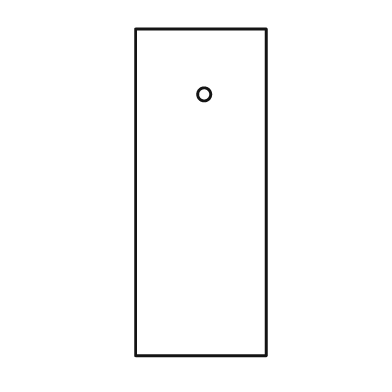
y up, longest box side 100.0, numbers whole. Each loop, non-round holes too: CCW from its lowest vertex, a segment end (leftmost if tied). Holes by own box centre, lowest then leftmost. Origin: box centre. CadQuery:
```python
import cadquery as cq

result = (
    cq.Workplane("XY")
    .moveTo(-20.0, -50.0)
    .lineTo(20.0, -50.0)
    .lineTo(20.0, 50.0)
    .lineTo(-20.0, 50.0)
    .close()
    .moveTo(1.0, 30.0)
    .circle(2.0)
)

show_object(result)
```